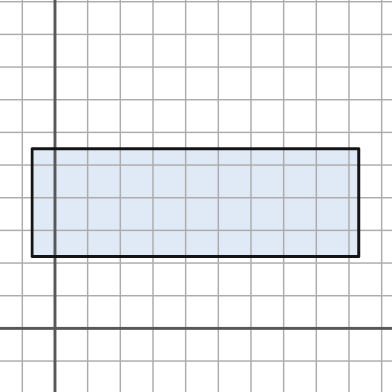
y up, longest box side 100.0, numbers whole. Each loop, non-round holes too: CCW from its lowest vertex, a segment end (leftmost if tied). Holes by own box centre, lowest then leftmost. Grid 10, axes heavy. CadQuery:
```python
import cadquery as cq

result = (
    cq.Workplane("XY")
    .moveTo(-7.0, 22.0)
    .lineTo(93.0, 22.0)
    .lineTo(93.0, 55.0)
    .lineTo(-7.0, 55.0)
    .close()
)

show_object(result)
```